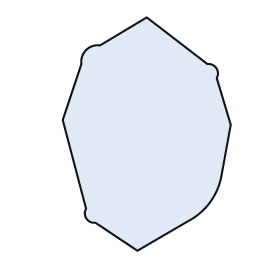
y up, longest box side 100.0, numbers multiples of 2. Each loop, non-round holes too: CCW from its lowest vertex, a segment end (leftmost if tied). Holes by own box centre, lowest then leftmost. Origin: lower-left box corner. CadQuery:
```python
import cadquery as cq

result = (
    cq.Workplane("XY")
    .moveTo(32.0, 0.0)
    .lineTo(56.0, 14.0)
    .threePointArc((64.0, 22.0), (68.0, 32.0))
    .lineTo(72.0, 54.0)
    .lineTo(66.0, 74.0)
    .threePointArc((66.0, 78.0), (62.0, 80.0))
    .lineTo(36.0, 100.0)
    .lineTo(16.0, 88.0)
    .threePointArc((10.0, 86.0), (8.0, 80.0))
    .lineTo(0.0, 56.0)
    .lineTo(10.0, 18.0)
    .threePointArc((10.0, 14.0), (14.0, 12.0))
    .close()
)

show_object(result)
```